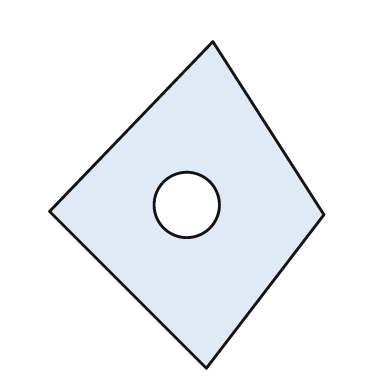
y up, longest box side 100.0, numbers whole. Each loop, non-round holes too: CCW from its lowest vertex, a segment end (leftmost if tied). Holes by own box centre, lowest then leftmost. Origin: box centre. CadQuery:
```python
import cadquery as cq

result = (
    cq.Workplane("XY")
    .moveTo(6.0, -50.0)
    .lineTo(42.0, -3.0)
    .lineTo(8.0, 50.0)
    .lineTo(-42.0, -2.0)
    .close()
    .moveTo(0.0, 0.0)
    .circle(10.0)
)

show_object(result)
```